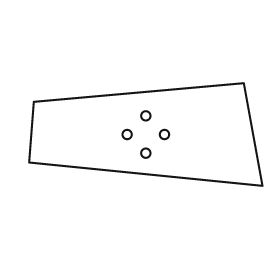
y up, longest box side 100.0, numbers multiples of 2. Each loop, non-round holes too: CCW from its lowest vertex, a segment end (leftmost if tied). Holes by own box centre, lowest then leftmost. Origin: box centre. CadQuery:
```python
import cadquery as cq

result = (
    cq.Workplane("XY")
    .moveTo(50.0, -22.0)
    .lineTo(42.0, 22.0)
    .lineTo(-48.0, 14.0)
    .lineTo(-50.0, -12.0)
    .close()
    .moveTo(0.0, -8.0)
    .circle(2.0)
    .moveTo(-8.0, 0.0)
    .circle(2.0)
    .moveTo(8.0, 0.0)
    .circle(2.0)
    .moveTo(0.0, 8.0)
    .circle(2.0)
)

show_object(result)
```